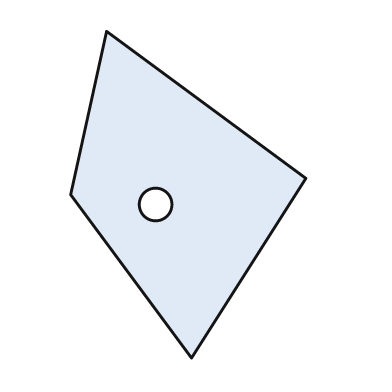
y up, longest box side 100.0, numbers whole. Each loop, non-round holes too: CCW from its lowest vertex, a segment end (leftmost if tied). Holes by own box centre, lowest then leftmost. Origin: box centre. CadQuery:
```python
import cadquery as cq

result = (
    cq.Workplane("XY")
    .moveTo(1.0, -50.0)
    .lineTo(36.0, 5.0)
    .lineTo(-25.0, 50.0)
    .lineTo(-36.0, 0.0)
    .close()
    .moveTo(-10.0, -3.0)
    .circle(5.0)
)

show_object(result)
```